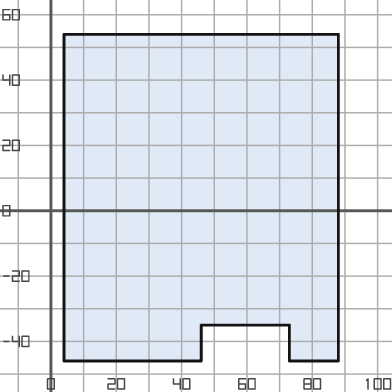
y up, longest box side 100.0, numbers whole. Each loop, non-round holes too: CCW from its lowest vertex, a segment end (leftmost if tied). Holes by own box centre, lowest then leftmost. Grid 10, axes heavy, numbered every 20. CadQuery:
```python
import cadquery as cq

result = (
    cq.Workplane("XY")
    .moveTo(4.0, -46.0)
    .lineTo(46.0, -46.0)
    .lineTo(46.0, -35.0)
    .lineTo(73.0, -35.0)
    .lineTo(73.0, -46.0)
    .lineTo(88.0, -46.0)
    .lineTo(88.0, 54.0)
    .lineTo(4.0, 54.0)
    .close()
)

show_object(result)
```